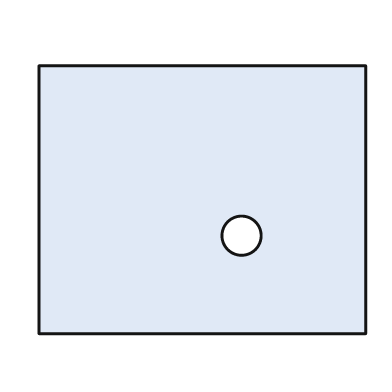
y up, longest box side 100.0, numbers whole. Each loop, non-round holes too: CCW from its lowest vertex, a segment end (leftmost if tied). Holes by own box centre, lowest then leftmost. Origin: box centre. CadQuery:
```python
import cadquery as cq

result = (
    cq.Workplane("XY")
    .moveTo(-50.0, -41.0)
    .lineTo(50.0, -41.0)
    .lineTo(50.0, 41.0)
    .lineTo(-50.0, 41.0)
    .close()
    .moveTo(12.0, -11.0)
    .circle(6.0)
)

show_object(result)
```